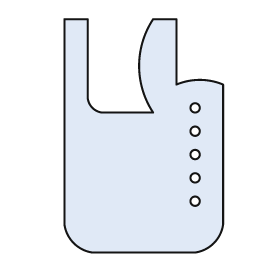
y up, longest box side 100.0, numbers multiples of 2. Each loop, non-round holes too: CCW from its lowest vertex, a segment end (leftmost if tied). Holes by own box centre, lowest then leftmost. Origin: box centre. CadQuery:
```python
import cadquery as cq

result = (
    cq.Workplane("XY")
    .moveTo(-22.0, -50.0)
    .lineTo(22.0, -50.0)
    .threePointArc((30.0, -46.0), (34.0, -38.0))
    .lineTo(34.0, 22.0)
    .threePointArc((24.0, 24.0), (14.0, 22.0))
    .lineTo(14.0, 50.0)
    .lineTo(4.0, 50.0)
    .threePointArc((-2.0, 30.0), (4.0, 10.0))
    .lineTo(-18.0, 10.0)
    .threePointArc((-22.0, 12.0), (-24.0, 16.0))
    .lineTo(-24.0, 50.0)
    .lineTo(-34.0, 50.0)
    .lineTo(-34.0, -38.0)
    .threePointArc((-30.0, -46.0), (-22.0, -50.0))
    .close()
    .moveTo(22.0, -28.0)
    .circle(2.0)
    .moveTo(22.0, -18.0)
    .circle(2.0)
    .moveTo(22.0, -8.0)
    .circle(2.0)
    .moveTo(22.0, 2.0)
    .circle(2.0)
    .moveTo(22.0, 12.0)
    .circle(2.0)
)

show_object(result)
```